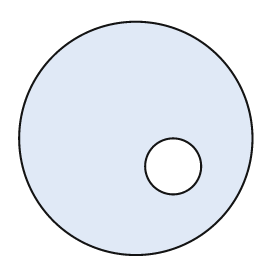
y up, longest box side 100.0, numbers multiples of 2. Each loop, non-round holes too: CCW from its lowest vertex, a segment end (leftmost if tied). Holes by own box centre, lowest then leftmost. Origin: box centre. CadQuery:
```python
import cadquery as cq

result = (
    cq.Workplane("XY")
    .moveTo(0.0, 0.0)
    .circle(50.0)
    .moveTo(16.0, -12.0)
    .circle(12.0)
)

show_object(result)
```